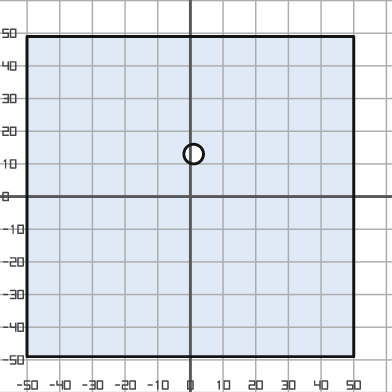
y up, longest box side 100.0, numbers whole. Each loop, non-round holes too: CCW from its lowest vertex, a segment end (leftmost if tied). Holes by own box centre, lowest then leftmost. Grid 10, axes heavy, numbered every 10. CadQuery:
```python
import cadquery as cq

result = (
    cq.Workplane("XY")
    .moveTo(-50.0, -49.0)
    .lineTo(50.0, -49.0)
    .lineTo(50.0, 49.0)
    .lineTo(-50.0, 49.0)
    .close()
    .moveTo(1.0, 13.0)
    .circle(3.0)
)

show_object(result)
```